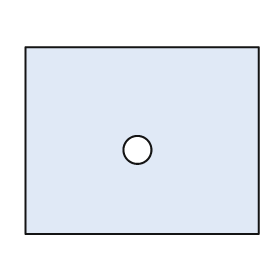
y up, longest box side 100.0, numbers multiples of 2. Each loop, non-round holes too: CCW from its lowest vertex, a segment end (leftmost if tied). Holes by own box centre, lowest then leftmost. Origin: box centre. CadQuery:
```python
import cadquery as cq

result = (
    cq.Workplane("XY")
    .moveTo(-50.0, -40.0)
    .lineTo(50.0, -40.0)
    .lineTo(50.0, 40.0)
    .lineTo(-50.0, 40.0)
    .close()
    .moveTo(-2.0, -4.0)
    .circle(6.0)
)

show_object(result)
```